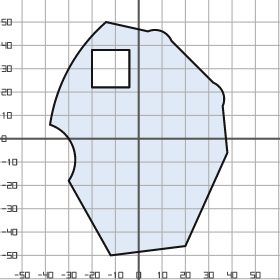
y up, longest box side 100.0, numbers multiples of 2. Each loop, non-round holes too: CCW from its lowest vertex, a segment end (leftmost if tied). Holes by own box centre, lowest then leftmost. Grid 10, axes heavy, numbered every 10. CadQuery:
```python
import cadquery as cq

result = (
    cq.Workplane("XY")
    .moveTo(-12.0, -50.0)
    .lineTo(20.0, -46.0)
    .lineTo(38.0, -6.0)
    .lineTo(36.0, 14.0)
    .threePointArc((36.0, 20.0), (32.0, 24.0))
    .lineTo(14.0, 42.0)
    .threePointArc((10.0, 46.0), (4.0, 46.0))
    .lineTo(-14.0, 50.0)
    .threePointArc((-30.0, 30.0), (-38.0, 6.0))
    .threePointArc((-28.0, -4.0), (-30.0, -18.0))
    .close()
    .moveTo(-20.0, 22.0)
    .lineTo(-4.0, 22.0)
    .lineTo(-4.0, 38.0)
    .lineTo(-20.0, 38.0)
    .close()
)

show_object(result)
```